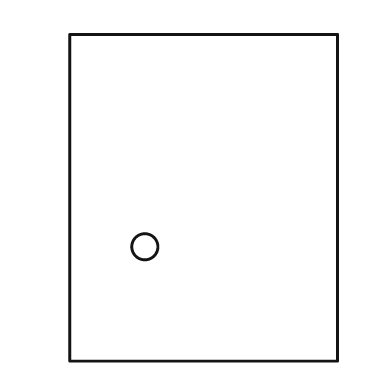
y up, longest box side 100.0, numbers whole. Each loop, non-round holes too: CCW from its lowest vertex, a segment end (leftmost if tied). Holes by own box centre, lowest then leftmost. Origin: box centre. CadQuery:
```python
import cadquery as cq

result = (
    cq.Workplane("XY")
    .moveTo(-41.0, -50.0)
    .lineTo(41.0, -50.0)
    .lineTo(41.0, 50.0)
    .lineTo(-41.0, 50.0)
    .close()
    .moveTo(-18.0, -15.0)
    .circle(4.0)
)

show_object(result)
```